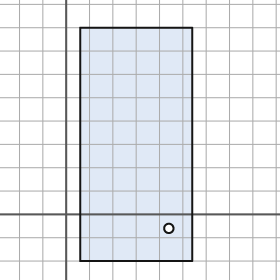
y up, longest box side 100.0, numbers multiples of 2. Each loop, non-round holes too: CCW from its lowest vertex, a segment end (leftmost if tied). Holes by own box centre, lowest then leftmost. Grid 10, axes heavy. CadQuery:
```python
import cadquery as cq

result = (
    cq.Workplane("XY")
    .moveTo(6.0, -20.0)
    .lineTo(54.0, -20.0)
    .lineTo(54.0, 80.0)
    .lineTo(6.0, 80.0)
    .close()
    .moveTo(44.0, -6.0)
    .circle(2.0)
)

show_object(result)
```